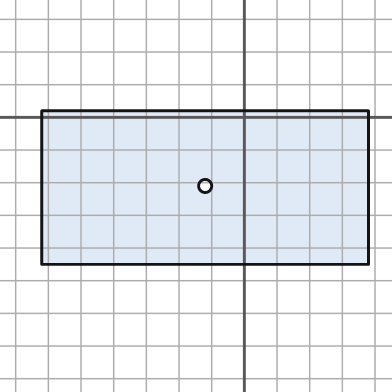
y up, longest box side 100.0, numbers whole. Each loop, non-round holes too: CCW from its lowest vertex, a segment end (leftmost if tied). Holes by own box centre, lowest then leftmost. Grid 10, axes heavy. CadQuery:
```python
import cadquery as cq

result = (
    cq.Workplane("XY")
    .moveTo(-62.0, -45.0)
    .lineTo(38.0, -45.0)
    .lineTo(38.0, 2.0)
    .lineTo(-62.0, 2.0)
    .close()
    .moveTo(-12.0, -21.0)
    .circle(2.0)
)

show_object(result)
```